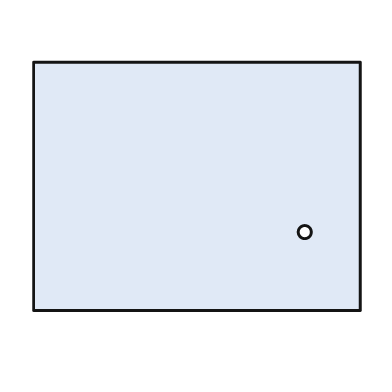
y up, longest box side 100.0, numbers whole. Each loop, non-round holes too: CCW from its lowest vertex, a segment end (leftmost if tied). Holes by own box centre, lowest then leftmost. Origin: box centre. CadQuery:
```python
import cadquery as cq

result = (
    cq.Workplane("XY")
    .moveTo(-50.0, -38.0)
    .lineTo(50.0, -38.0)
    .lineTo(50.0, 38.0)
    .lineTo(-50.0, 38.0)
    .close()
    .moveTo(33.0, -14.0)
    .circle(2.0)
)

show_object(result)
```